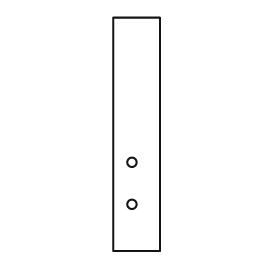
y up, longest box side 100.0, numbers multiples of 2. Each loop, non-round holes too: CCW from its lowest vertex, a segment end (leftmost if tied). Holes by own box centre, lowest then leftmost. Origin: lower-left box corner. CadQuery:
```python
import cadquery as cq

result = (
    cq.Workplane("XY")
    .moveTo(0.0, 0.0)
    .lineTo(20.0, 0.0)
    .lineTo(20.0, 100.0)
    .lineTo(0.0, 100.0)
    .close()
    .moveTo(8.0, 20.0)
    .circle(2.0)
    .moveTo(8.0, 38.0)
    .circle(2.0)
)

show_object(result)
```